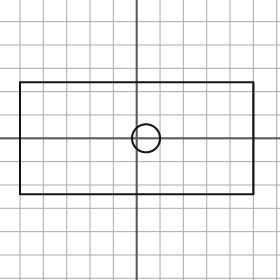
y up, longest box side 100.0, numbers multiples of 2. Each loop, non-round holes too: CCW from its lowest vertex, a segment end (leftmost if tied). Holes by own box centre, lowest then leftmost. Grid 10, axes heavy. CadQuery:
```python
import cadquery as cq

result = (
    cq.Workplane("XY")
    .moveTo(-50.0, -24.0)
    .lineTo(50.0, -24.0)
    .lineTo(50.0, 24.0)
    .lineTo(-50.0, 24.0)
    .close()
    .moveTo(4.0, 0.0)
    .circle(6.0)
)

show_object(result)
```